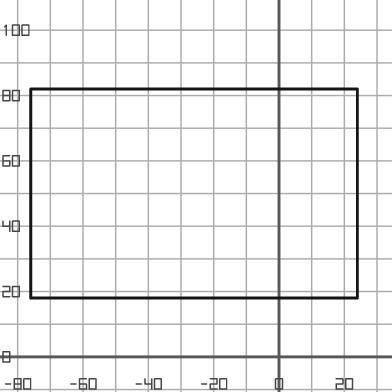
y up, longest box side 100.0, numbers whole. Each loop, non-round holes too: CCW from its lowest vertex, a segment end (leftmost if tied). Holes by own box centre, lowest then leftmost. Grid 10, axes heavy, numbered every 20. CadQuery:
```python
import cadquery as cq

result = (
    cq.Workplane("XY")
    .moveTo(-76.0, 18.0)
    .lineTo(24.0, 18.0)
    .lineTo(24.0, 82.0)
    .lineTo(-76.0, 82.0)
    .close()
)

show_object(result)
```